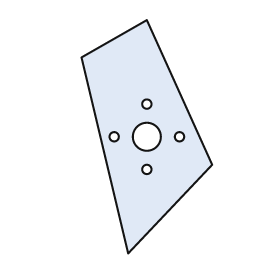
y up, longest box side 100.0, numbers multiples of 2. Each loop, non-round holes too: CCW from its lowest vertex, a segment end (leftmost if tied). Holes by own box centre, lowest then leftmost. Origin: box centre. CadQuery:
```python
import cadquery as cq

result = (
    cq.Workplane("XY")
    .moveTo(-8.0, -50.0)
    .lineTo(28.0, -12.0)
    .lineTo(0.0, 50.0)
    .lineTo(-28.0, 34.0)
    .close()
    .moveTo(0.0, -14.0)
    .circle(2.0)
    .moveTo(-14.0, 0.0)
    .circle(2.0)
    .moveTo(0.0, 0.0)
    .circle(6.0)
    .moveTo(14.0, 0.0)
    .circle(2.0)
    .moveTo(0.0, 14.0)
    .circle(2.0)
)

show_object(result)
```